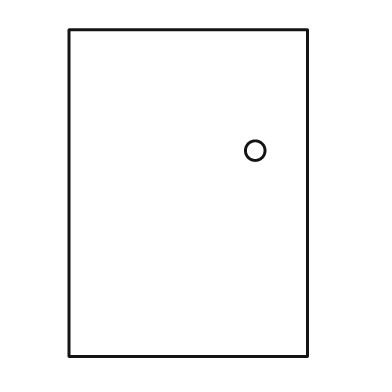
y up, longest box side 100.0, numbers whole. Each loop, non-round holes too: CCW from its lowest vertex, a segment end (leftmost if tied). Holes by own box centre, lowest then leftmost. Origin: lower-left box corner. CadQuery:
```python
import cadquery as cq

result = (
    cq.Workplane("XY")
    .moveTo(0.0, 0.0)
    .lineTo(73.0, 0.0)
    .lineTo(73.0, 100.0)
    .lineTo(0.0, 100.0)
    .close()
    .moveTo(57.0, 63.0)
    .circle(3.0)
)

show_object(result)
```